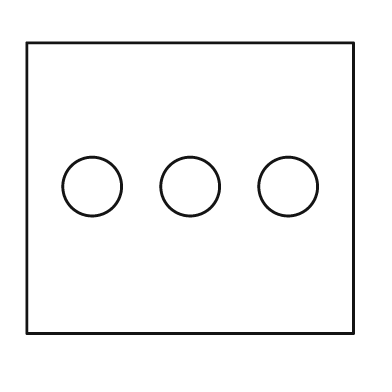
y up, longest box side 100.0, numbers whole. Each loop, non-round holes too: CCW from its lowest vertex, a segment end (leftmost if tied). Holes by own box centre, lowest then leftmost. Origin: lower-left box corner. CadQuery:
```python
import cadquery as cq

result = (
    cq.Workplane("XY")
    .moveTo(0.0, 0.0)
    .lineTo(100.0, 0.0)
    .lineTo(100.0, 89.0)
    .lineTo(0.0, 89.0)
    .close()
    .moveTo(20.0, 45.0)
    .circle(9.0)
    .moveTo(50.0, 45.0)
    .circle(9.0)
    .moveTo(80.0, 45.0)
    .circle(9.0)
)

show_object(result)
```